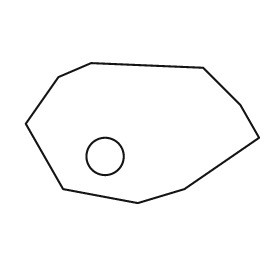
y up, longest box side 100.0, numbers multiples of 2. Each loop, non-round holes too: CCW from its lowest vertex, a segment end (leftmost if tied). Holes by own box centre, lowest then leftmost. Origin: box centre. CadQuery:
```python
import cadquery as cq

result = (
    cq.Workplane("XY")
    .moveTo(-2.0, -30.0)
    .lineTo(18.0, -24.0)
    .lineTo(50.0, -2.0)
    .lineTo(42.0, 12.0)
    .lineTo(26.0, 28.0)
    .lineTo(-22.0, 30.0)
    .lineTo(-36.0, 24.0)
    .lineTo(-50.0, 4.0)
    .lineTo(-34.0, -24.0)
    .close()
    .moveTo(-16.0, -10.0)
    .circle(8.0)
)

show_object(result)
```